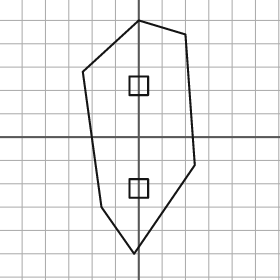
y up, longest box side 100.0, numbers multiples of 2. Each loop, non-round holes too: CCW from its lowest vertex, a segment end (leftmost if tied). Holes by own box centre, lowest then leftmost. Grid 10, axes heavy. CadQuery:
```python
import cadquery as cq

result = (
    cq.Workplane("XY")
    .moveTo(-2.0, -50.0)
    .lineTo(24.0, -12.0)
    .lineTo(20.0, 44.0)
    .lineTo(0.0, 50.0)
    .lineTo(-24.0, 28.0)
    .lineTo(-16.0, -30.0)
    .close()
    .moveTo(-4.0, -26.0)
    .lineTo(4.0, -26.0)
    .lineTo(4.0, -18.0)
    .lineTo(-4.0, -18.0)
    .close()
    .moveTo(-4.0, 18.0)
    .lineTo(4.0, 18.0)
    .lineTo(4.0, 26.0)
    .lineTo(-4.0, 26.0)
    .close()
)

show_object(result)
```